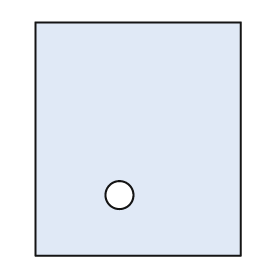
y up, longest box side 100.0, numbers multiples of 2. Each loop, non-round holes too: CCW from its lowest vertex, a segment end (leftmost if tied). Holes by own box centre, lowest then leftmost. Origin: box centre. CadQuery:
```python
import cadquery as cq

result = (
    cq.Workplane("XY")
    .moveTo(-44.0, -50.0)
    .lineTo(44.0, -50.0)
    .lineTo(44.0, 50.0)
    .lineTo(-44.0, 50.0)
    .close()
    .moveTo(-8.0, -24.0)
    .circle(6.0)
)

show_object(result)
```